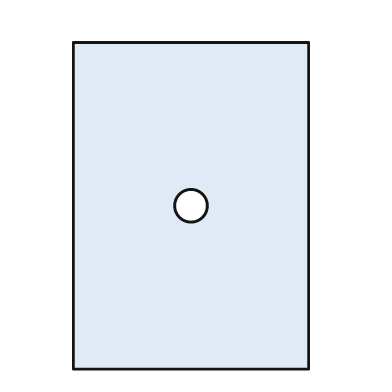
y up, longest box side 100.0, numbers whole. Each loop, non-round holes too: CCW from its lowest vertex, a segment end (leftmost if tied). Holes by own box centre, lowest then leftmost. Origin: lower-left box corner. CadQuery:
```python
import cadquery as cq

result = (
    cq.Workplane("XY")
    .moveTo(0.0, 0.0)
    .lineTo(72.0, 0.0)
    .lineTo(72.0, 100.0)
    .lineTo(0.0, 100.0)
    .close()
    .moveTo(36.0, 50.0)
    .circle(5.0)
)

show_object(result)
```